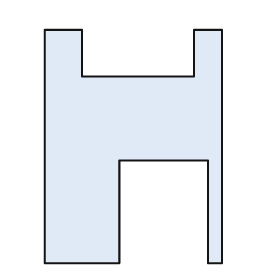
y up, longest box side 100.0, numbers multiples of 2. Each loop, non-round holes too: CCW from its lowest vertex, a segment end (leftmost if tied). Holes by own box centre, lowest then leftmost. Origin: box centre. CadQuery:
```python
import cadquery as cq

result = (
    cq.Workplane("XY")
    .moveTo(-38.0, -50.0)
    .lineTo(-6.0, -50.0)
    .lineTo(-6.0, -6.0)
    .lineTo(32.0, -6.0)
    .lineTo(32.0, -50.0)
    .lineTo(38.0, -50.0)
    .lineTo(38.0, 50.0)
    .lineTo(26.0, 50.0)
    .lineTo(26.0, 30.0)
    .lineTo(-22.0, 30.0)
    .lineTo(-22.0, 50.0)
    .lineTo(-38.0, 50.0)
    .close()
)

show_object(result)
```